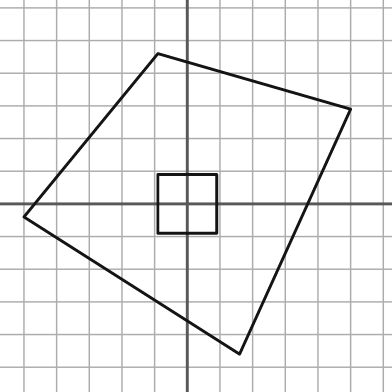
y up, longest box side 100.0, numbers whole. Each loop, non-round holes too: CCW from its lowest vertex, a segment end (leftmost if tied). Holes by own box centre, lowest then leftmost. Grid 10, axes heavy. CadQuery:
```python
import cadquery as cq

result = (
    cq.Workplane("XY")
    .moveTo(16.0, -46.0)
    .lineTo(50.0, 29.0)
    .lineTo(-9.0, 46.0)
    .lineTo(-50.0, -4.0)
    .close()
    .moveTo(-9.0, -9.0)
    .lineTo(9.0, -9.0)
    .lineTo(9.0, 9.0)
    .lineTo(-9.0, 9.0)
    .close()
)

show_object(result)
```